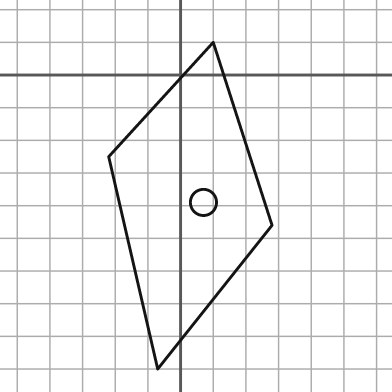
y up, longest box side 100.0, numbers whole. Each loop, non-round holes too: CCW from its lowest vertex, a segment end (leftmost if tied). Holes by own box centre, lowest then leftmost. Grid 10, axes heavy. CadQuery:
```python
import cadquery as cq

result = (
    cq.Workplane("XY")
    .moveTo(-7.0, -90.0)
    .lineTo(28.0, -46.0)
    .lineTo(10.0, 10.0)
    .lineTo(-22.0, -25.0)
    .close()
    .moveTo(7.0, -39.0)
    .circle(4.0)
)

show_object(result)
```